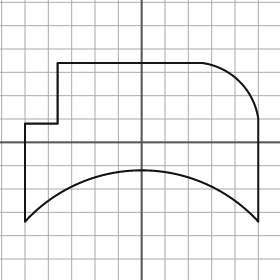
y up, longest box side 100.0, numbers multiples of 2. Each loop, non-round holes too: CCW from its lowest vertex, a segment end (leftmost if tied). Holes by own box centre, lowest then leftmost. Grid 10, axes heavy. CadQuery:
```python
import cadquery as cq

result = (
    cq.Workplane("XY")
    .moveTo(-50.0, -34.0)
    .threePointArc((0.0, -12.0), (50.0, -34.0))
    .lineTo(50.0, 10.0)
    .threePointArc((42.0, 26.0), (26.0, 34.0))
    .lineTo(-36.0, 34.0)
    .lineTo(-36.0, 8.0)
    .lineTo(-50.0, 8.0)
    .close()
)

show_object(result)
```